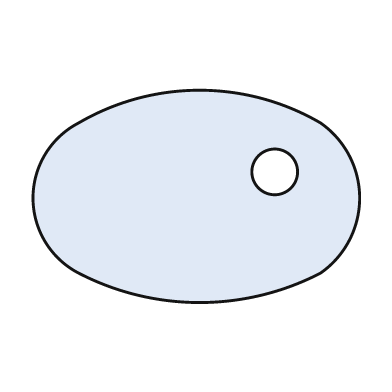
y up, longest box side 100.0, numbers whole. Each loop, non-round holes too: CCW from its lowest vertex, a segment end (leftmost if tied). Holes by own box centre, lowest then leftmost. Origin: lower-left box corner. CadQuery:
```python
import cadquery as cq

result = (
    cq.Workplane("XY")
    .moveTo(14.0, 9.0)
    .threePointArc((51.0, 0.0), (88.0, 9.0))
    .threePointArc((100.0, 32.0), (88.0, 55.0))
    .threePointArc((51.0, 65.0), (14.0, 55.0))
    .threePointArc((0.0, 32.0), (14.0, 9.0))
    .close()
    .moveTo(74.0, 40.0)
    .circle(7.0)
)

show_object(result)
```